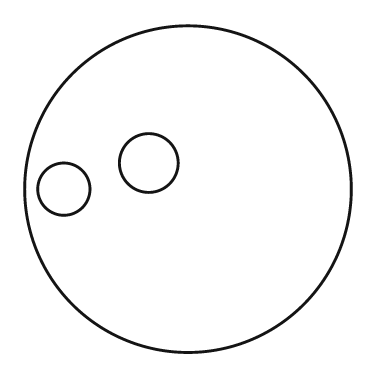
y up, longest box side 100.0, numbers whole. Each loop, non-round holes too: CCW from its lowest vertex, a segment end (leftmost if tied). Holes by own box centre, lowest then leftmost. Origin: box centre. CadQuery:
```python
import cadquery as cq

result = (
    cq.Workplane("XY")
    .moveTo(0.0, 0.0)
    .circle(50.0)
    .moveTo(-38.0, 0.0)
    .circle(8.0)
    .moveTo(-12.0, 8.0)
    .circle(9.0)
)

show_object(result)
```